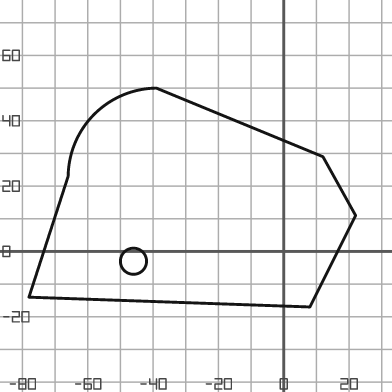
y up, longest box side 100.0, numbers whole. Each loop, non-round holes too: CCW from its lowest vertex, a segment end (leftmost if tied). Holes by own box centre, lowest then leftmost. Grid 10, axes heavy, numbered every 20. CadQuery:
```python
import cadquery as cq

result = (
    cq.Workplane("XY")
    .moveTo(8.0, -17.0)
    .lineTo(22.0, 11.0)
    .lineTo(12.0, 29.0)
    .lineTo(-39.0, 50.0)
    .threePointArc((-58.0, 42.0), (-66.0, 23.0))
    .lineTo(-78.0, -14.0)
    .close()
    .moveTo(-46.0, -3.0)
    .circle(4.0)
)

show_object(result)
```